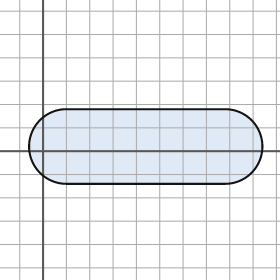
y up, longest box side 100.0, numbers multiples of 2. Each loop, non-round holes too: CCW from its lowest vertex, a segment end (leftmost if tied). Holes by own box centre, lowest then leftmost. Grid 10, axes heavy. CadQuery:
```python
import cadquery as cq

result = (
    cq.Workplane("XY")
    .moveTo(10.0, -14.0)
    .lineTo(78.0, -14.0)
    .threePointArc((94.0, 2.0), (78.0, 18.0))
    .lineTo(10.0, 18.0)
    .threePointArc((-6.0, 2.0), (10.0, -14.0))
    .close()
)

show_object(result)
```